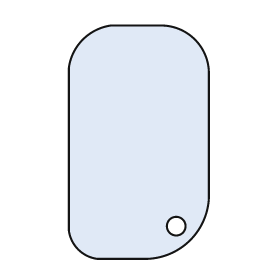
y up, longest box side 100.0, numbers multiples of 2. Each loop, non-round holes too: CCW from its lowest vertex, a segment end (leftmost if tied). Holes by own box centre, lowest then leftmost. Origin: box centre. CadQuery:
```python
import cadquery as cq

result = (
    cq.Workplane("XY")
    .moveTo(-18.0, -50.0)
    .lineTo(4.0, -50.0)
    .threePointArc((22.0, -42.0), (30.0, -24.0))
    .lineTo(30.0, 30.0)
    .threePointArc((24.0, 44.0), (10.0, 50.0))
    .lineTo(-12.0, 50.0)
    .threePointArc((-24.0, 44.0), (-30.0, 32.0))
    .lineTo(-30.0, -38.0)
    .threePointArc((-26.0, -46.0), (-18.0, -50.0))
    .close()
    .moveTo(16.0, -36.0)
    .circle(4.0)
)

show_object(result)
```